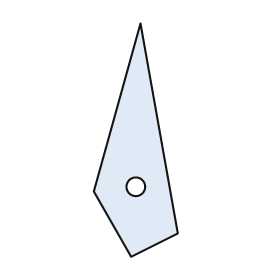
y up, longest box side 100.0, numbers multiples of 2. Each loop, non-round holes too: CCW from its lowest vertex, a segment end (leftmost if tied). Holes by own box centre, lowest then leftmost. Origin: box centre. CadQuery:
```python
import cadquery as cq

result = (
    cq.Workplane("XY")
    .moveTo(-2.0, -50.0)
    .lineTo(18.0, -40.0)
    .lineTo(2.0, 50.0)
    .lineTo(-18.0, -22.0)
    .close()
    .moveTo(0.0, -20.0)
    .circle(4.0)
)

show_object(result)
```